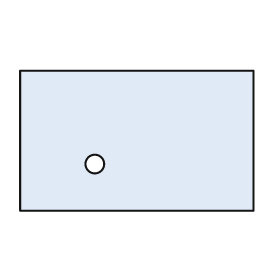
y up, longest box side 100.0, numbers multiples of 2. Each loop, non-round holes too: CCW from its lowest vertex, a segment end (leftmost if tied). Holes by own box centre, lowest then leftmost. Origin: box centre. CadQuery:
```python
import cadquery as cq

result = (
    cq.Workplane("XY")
    .moveTo(-50.0, -30.0)
    .lineTo(50.0, -30.0)
    .lineTo(50.0, 30.0)
    .lineTo(-50.0, 30.0)
    .close()
    .moveTo(-18.0, -10.0)
    .circle(4.0)
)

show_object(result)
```